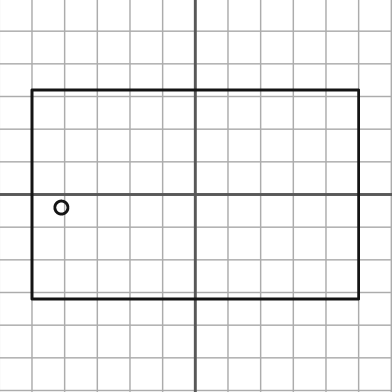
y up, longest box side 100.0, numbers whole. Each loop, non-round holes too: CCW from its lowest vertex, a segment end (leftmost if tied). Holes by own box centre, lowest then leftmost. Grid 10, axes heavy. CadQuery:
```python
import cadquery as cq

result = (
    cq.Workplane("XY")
    .moveTo(-50.0, -32.0)
    .lineTo(50.0, -32.0)
    .lineTo(50.0, 32.0)
    .lineTo(-50.0, 32.0)
    .close()
    .moveTo(-41.0, -4.0)
    .circle(2.0)
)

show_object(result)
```